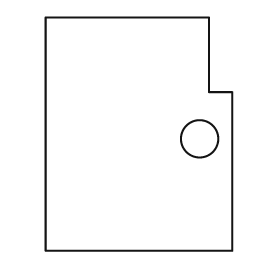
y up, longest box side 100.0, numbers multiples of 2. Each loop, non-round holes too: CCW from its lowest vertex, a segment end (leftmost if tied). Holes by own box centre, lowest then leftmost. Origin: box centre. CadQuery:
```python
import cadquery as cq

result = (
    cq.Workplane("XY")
    .moveTo(-40.0, -50.0)
    .lineTo(40.0, -50.0)
    .lineTo(40.0, 18.0)
    .lineTo(30.0, 18.0)
    .lineTo(30.0, 50.0)
    .lineTo(-40.0, 50.0)
    .close()
    .moveTo(26.0, -2.0)
    .circle(8.0)
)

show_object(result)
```